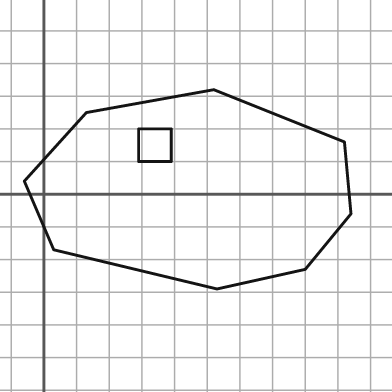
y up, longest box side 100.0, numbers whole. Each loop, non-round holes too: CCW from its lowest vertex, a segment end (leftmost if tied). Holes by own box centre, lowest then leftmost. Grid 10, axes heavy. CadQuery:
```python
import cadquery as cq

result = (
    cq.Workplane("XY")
    .moveTo(53.0, -29.0)
    .lineTo(80.0, -23.0)
    .lineTo(94.0, -6.0)
    .lineTo(92.0, 16.0)
    .lineTo(52.0, 32.0)
    .lineTo(13.0, 25.0)
    .lineTo(-6.0, 4.0)
    .lineTo(3.0, -17.0)
    .close()
    .moveTo(29.0, 10.0)
    .lineTo(39.0, 10.0)
    .lineTo(39.0, 20.0)
    .lineTo(29.0, 20.0)
    .close()
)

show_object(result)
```